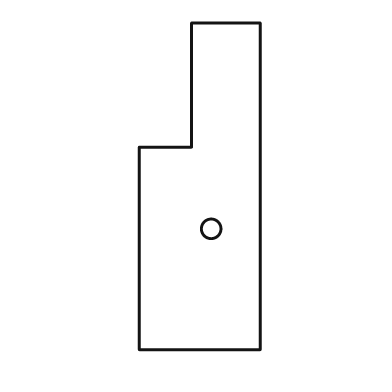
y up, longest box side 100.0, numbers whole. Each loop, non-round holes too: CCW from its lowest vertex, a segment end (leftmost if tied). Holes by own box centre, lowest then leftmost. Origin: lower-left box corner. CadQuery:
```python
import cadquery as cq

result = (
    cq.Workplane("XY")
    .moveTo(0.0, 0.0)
    .lineTo(37.0, 0.0)
    .lineTo(37.0, 100.0)
    .lineTo(16.0, 100.0)
    .lineTo(16.0, 62.0)
    .lineTo(0.0, 62.0)
    .close()
    .moveTo(22.0, 37.0)
    .circle(3.0)
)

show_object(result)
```